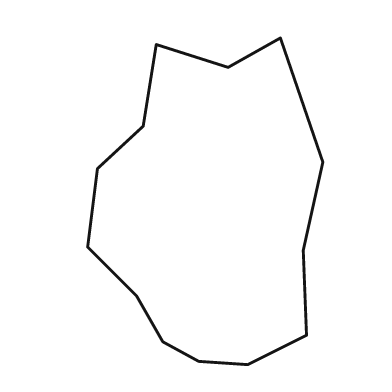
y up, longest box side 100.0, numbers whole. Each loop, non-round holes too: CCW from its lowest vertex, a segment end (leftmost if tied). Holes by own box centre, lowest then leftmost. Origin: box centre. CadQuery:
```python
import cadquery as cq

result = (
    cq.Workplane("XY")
    .moveTo(13.0, -50.0)
    .lineTo(31.0, -41.0)
    .lineTo(30.0, -15.0)
    .lineTo(36.0, 12.0)
    .lineTo(23.0, 50.0)
    .lineTo(7.0, 41.0)
    .lineTo(-15.0, 48.0)
    .lineTo(-19.0, 23.0)
    .lineTo(-33.0, 10.0)
    .lineTo(-36.0, -14.0)
    .lineTo(-21.0, -29.0)
    .lineTo(-13.0, -43.0)
    .lineTo(-2.0, -49.0)
    .close()
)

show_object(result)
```